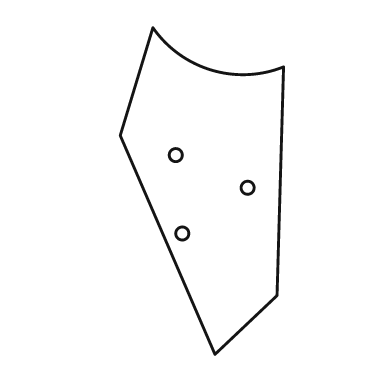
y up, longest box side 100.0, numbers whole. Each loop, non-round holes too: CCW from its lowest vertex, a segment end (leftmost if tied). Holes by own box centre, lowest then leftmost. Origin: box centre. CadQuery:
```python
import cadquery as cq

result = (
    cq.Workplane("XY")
    .moveTo(4.0, -50.0)
    .lineTo(23.0, -32.0)
    .lineTo(25.0, 38.0)
    .threePointArc((3.0, 37.0), (-15.0, 50.0))
    .lineTo(-25.0, 17.0)
    .close()
    .moveTo(-6.0, -13.0)
    .circle(2.0)
    .moveTo(14.0, 1.0)
    .circle(2.0)
    .moveTo(-8.0, 11.0)
    .circle(2.0)
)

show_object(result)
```